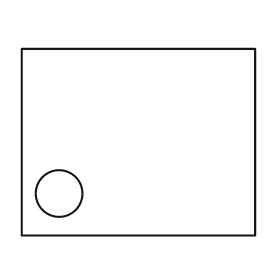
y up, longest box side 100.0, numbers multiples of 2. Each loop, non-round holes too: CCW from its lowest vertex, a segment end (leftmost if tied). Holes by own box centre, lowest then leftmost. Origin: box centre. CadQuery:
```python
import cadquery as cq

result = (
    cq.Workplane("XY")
    .moveTo(-50.0, -40.0)
    .lineTo(50.0, -40.0)
    .lineTo(50.0, 40.0)
    .lineTo(-50.0, 40.0)
    .close()
    .moveTo(-34.0, -22.0)
    .circle(10.0)
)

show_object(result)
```